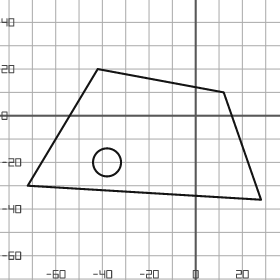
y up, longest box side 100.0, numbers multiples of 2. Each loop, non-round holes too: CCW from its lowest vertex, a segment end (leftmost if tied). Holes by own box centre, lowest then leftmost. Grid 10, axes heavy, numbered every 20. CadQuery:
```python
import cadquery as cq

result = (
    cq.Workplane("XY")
    .moveTo(28.0, -36.0)
    .lineTo(12.0, 10.0)
    .lineTo(-42.0, 20.0)
    .lineTo(-72.0, -30.0)
    .close()
    .moveTo(-38.0, -20.0)
    .circle(6.0)
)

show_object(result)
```